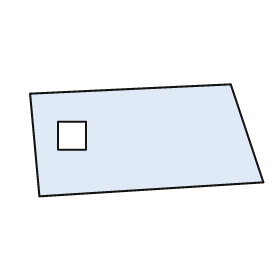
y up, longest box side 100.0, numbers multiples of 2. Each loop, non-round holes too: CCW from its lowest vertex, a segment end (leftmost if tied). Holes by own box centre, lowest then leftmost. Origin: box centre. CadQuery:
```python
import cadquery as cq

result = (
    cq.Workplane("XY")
    .moveTo(-46.0, -24.0)
    .lineTo(50.0, -18.0)
    .lineTo(36.0, 24.0)
    .lineTo(-50.0, 20.0)
    .close()
    .moveTo(-38.0, -4.0)
    .lineTo(-26.0, -4.0)
    .lineTo(-26.0, 8.0)
    .lineTo(-38.0, 8.0)
    .close()
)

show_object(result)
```